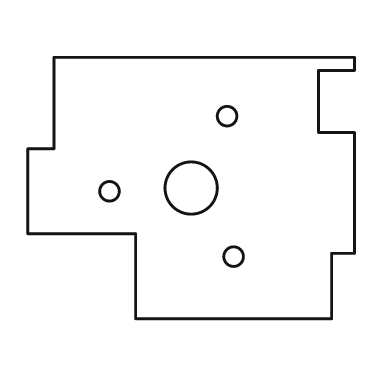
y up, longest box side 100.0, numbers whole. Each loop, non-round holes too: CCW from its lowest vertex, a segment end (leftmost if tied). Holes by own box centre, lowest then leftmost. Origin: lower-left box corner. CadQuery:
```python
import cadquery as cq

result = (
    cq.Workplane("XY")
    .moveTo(33.0, 0.0)
    .lineTo(93.0, 0.0)
    .lineTo(93.0, 20.0)
    .lineTo(100.0, 20.0)
    .lineTo(100.0, 57.0)
    .lineTo(89.0, 57.0)
    .lineTo(89.0, 76.0)
    .lineTo(100.0, 76.0)
    .lineTo(100.0, 80.0)
    .lineTo(8.0, 80.0)
    .lineTo(8.0, 52.0)
    .lineTo(0.0, 52.0)
    .lineTo(0.0, 26.0)
    .lineTo(33.0, 26.0)
    .close()
    .moveTo(63.0, 19.0)
    .circle(3.0)
    .moveTo(25.0, 39.0)
    .circle(3.0)
    .moveTo(50.0, 40.0)
    .circle(8.0)
    .moveTo(61.0, 62.0)
    .circle(3.0)
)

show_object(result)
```